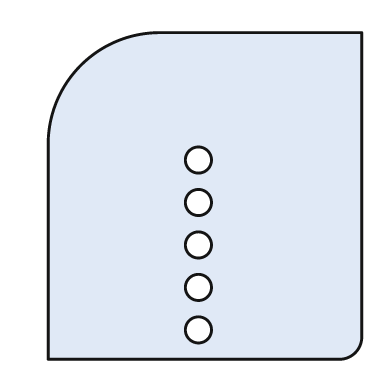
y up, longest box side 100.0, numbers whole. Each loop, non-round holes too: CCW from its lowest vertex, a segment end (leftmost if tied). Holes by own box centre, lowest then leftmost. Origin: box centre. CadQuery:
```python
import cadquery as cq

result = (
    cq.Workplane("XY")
    .moveTo(-48.0, -50.0)
    .lineTo(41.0, -50.0)
    .threePointArc((46.0, -48.0), (48.0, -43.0))
    .lineTo(48.0, 50.0)
    .lineTo(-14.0, 50.0)
    .threePointArc((-38.0, 40.0), (-48.0, 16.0))
    .close()
    .moveTo(-2.0, -41.0)
    .circle(4.0)
    .moveTo(-2.0, -28.0)
    .circle(4.0)
    .moveTo(-2.0, -15.0)
    .circle(4.0)
    .moveTo(-2.0, -2.0)
    .circle(4.0)
    .moveTo(-2.0, 11.0)
    .circle(4.0)
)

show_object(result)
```